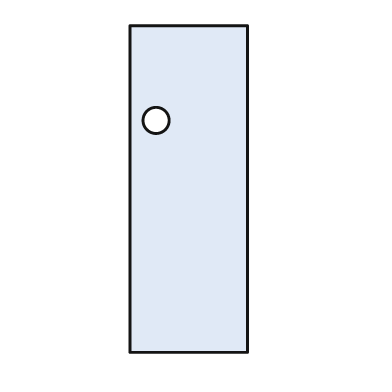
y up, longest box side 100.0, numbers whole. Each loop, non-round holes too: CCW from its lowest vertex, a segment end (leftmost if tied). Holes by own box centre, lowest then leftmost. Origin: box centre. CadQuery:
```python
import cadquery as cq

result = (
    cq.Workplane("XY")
    .moveTo(-18.0, -50.0)
    .lineTo(18.0, -50.0)
    .lineTo(18.0, 50.0)
    .lineTo(-18.0, 50.0)
    .close()
    .moveTo(-10.0, 21.0)
    .circle(4.0)
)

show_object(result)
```